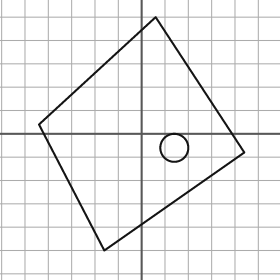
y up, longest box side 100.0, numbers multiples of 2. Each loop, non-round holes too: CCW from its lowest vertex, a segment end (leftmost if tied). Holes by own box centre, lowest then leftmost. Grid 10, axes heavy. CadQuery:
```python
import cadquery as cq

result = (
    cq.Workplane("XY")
    .moveTo(-16.0, -50.0)
    .lineTo(44.0, -8.0)
    .lineTo(6.0, 50.0)
    .lineTo(-44.0, 4.0)
    .close()
    .moveTo(14.0, -6.0)
    .circle(6.0)
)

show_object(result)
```